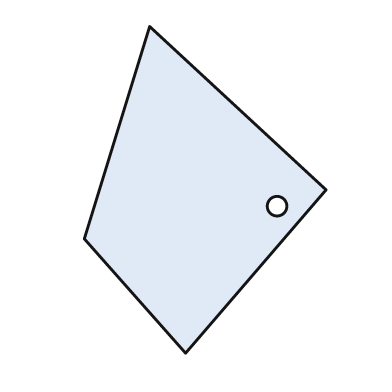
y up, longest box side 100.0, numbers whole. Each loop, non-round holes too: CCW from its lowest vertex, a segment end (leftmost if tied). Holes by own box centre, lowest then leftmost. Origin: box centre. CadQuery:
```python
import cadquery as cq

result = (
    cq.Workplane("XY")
    .moveTo(-6.0, -50.0)
    .lineTo(37.0, 0.0)
    .lineTo(-17.0, 50.0)
    .lineTo(-37.0, -15.0)
    .close()
    .moveTo(22.0, -5.0)
    .circle(3.0)
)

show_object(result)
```